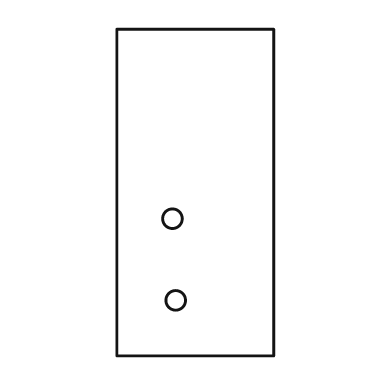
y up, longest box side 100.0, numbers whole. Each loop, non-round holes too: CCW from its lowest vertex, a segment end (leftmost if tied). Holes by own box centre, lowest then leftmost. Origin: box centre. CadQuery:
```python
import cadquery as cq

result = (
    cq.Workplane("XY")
    .moveTo(-24.0, -50.0)
    .lineTo(24.0, -50.0)
    .lineTo(24.0, 50.0)
    .lineTo(-24.0, 50.0)
    .close()
    .moveTo(-6.0, -33.0)
    .circle(3.0)
    .moveTo(-7.0, -8.0)
    .circle(3.0)
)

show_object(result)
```